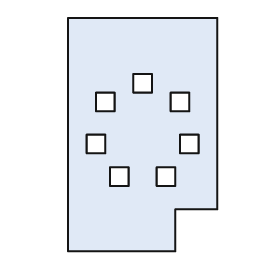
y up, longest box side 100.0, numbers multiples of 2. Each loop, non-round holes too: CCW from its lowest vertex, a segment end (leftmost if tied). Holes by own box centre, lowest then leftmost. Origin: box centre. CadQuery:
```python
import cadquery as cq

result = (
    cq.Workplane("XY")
    .moveTo(-32.0, -50.0)
    .lineTo(14.0, -50.0)
    .lineTo(14.0, -32.0)
    .lineTo(32.0, -32.0)
    .lineTo(32.0, 50.0)
    .lineTo(-32.0, 50.0)
    .close()
    .moveTo(-14.0, -22.0)
    .lineTo(-6.0, -22.0)
    .lineTo(-6.0, -14.0)
    .lineTo(-14.0, -14.0)
    .close()
    .moveTo(6.0, -22.0)
    .lineTo(14.0, -22.0)
    .lineTo(14.0, -14.0)
    .lineTo(6.0, -14.0)
    .close()
    .moveTo(-24.0, -8.0)
    .lineTo(-16.0, -8.0)
    .lineTo(-16.0, 0.0)
    .lineTo(-24.0, 0.0)
    .close()
    .moveTo(16.0, -8.0)
    .lineTo(24.0, -8.0)
    .lineTo(24.0, 0.0)
    .lineTo(16.0, 0.0)
    .close()
    .moveTo(-20.0, 10.0)
    .lineTo(-12.0, 10.0)
    .lineTo(-12.0, 18.0)
    .lineTo(-20.0, 18.0)
    .close()
    .moveTo(12.0, 10.0)
    .lineTo(20.0, 10.0)
    .lineTo(20.0, 18.0)
    .lineTo(12.0, 18.0)
    .close()
    .moveTo(-4.0, 18.0)
    .lineTo(4.0, 18.0)
    .lineTo(4.0, 26.0)
    .lineTo(-4.0, 26.0)
    .close()
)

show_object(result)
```